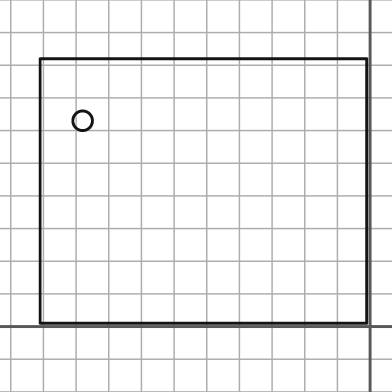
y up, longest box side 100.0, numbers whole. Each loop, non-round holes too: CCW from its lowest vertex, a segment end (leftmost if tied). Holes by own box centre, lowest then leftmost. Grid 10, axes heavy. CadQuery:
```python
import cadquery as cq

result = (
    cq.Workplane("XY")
    .moveTo(-101.0, 1.0)
    .lineTo(-1.0, 1.0)
    .lineTo(-1.0, 82.0)
    .lineTo(-101.0, 82.0)
    .close()
    .moveTo(-88.0, 63.0)
    .circle(3.0)
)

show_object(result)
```